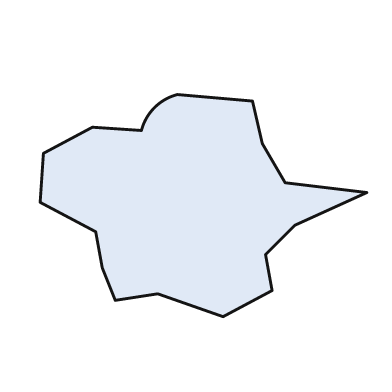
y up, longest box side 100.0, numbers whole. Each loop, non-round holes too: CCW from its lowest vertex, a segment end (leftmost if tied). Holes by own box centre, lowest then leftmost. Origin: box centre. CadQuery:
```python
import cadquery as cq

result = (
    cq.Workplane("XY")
    .moveTo(6.0, -34.0)
    .lineTo(21.0, -26.0)
    .lineTo(19.0, -15.0)
    .lineTo(28.0, -6.0)
    .lineTo(50.0, 4.0)
    .lineTo(25.0, 7.0)
    .lineTo(18.0, 19.0)
    .lineTo(15.0, 32.0)
    .lineTo(-8.0, 34.0)
    .threePointArc((-15.0, 30.0), (-19.0, 23.0))
    .lineTo(-34.0, 24.0)
    .lineTo(-49.0, 16.0)
    .lineTo(-50.0, 1.0)
    .lineTo(-33.0, -8.0)
    .lineTo(-31.0, -19.0)
    .lineTo(-27.0, -29.0)
    .lineTo(-14.0, -27.0)
    .close()
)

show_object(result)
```